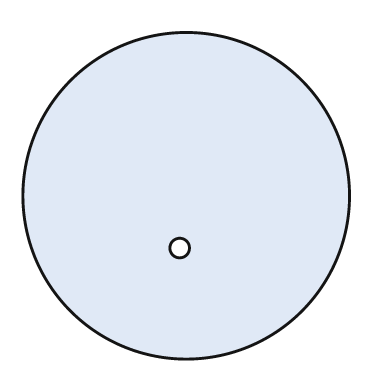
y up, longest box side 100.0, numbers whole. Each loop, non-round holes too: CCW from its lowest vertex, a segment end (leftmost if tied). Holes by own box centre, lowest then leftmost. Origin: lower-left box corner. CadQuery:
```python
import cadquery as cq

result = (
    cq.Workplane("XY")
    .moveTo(50.0, 50.0)
    .circle(50.0)
    .moveTo(48.0, 34.0)
    .circle(3.0)
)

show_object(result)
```